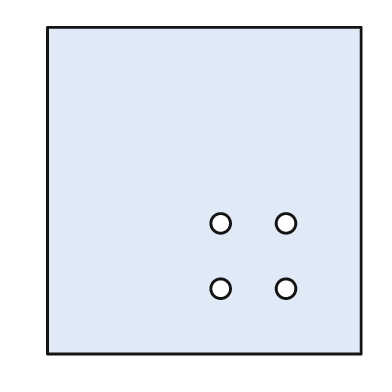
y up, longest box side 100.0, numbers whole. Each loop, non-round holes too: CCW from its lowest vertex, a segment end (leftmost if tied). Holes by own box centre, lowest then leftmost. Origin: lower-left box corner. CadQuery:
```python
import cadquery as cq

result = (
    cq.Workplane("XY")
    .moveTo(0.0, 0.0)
    .lineTo(96.0, 0.0)
    .lineTo(96.0, 100.0)
    .lineTo(0.0, 100.0)
    .close()
    .moveTo(53.0, 20.0)
    .circle(3.0)
    .moveTo(73.0, 20.0)
    .circle(3.0)
    .moveTo(53.0, 40.0)
    .circle(3.0)
    .moveTo(73.0, 40.0)
    .circle(3.0)
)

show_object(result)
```